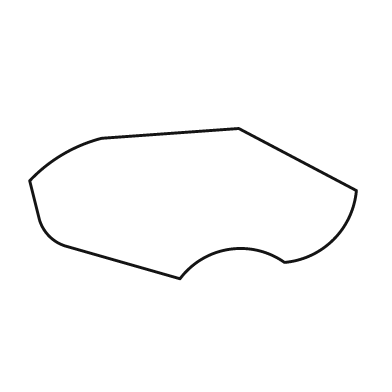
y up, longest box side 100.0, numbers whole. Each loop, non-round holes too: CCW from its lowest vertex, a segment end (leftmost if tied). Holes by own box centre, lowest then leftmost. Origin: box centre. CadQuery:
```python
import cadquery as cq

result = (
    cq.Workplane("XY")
    .moveTo(-4.0, -23.0)
    .threePointArc((11.0, -14.0), (28.0, -18.0))
    .threePointArc((43.0, -11.0), (50.0, 4.0))
    .lineTo(14.0, 23.0)
    .lineTo(-28.0, 20.0)
    .threePointArc((-40.0, 15.0), (-50.0, 7.0))
    .lineTo(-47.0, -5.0)
    .threePointArc((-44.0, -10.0), (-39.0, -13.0))
    .close()
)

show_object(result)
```